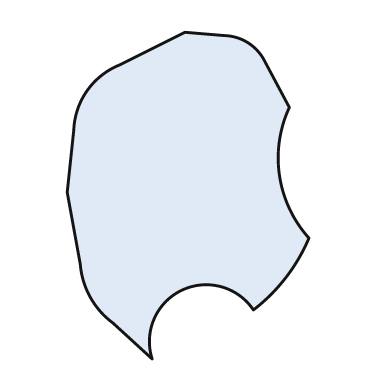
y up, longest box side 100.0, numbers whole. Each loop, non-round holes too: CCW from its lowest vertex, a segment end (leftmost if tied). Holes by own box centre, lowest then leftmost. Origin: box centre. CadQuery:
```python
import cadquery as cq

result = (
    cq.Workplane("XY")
    .moveTo(-11.0, -50.0)
    .threePointArc((-2.0, -29.0), (20.0, -35.0))
    .threePointArc((30.0, -25.0), (37.0, -13.0))
    .threePointArc((28.0, 6.0), (31.0, 27.0))
    .lineTo(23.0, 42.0)
    .threePointArc((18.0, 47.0), (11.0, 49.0))
    .lineTo(-1.0, 50.0)
    .lineTo(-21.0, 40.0)
    .threePointArc((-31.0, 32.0), (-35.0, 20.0))
    .lineTo(-37.0, 1.0)
    .lineTo(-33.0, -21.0)
    .threePointArc((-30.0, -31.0), (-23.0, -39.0))
    .close()
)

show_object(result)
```